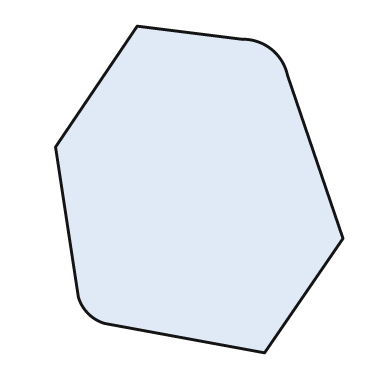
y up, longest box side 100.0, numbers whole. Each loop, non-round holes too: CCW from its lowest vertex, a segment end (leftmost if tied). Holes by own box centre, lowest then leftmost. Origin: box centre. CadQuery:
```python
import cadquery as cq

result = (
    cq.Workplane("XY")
    .moveTo(20.0, -50.0)
    .lineTo(44.0, -15.0)
    .lineTo(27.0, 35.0)
    .threePointArc((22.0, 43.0), (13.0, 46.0))
    .lineTo(-19.0, 50.0)
    .lineTo(-44.0, 13.0)
    .lineTo(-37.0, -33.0)
    .threePointArc((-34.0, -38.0), (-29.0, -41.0))
    .close()
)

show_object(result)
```